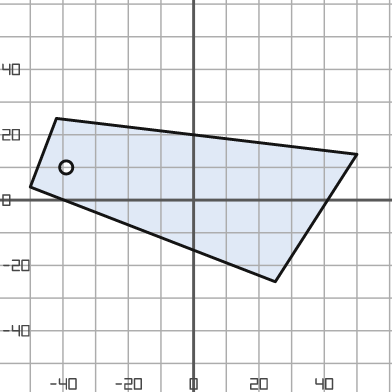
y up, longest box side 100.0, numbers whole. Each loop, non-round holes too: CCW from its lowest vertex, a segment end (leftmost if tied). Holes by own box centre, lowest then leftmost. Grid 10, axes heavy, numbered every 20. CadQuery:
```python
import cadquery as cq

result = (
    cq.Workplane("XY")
    .moveTo(25.0, -25.0)
    .lineTo(50.0, 14.0)
    .lineTo(-42.0, 25.0)
    .lineTo(-50.0, 4.0)
    .close()
    .moveTo(-39.0, 10.0)
    .circle(2.0)
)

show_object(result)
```